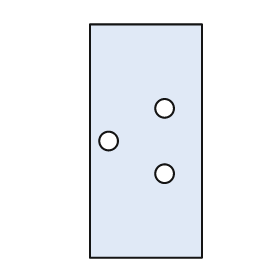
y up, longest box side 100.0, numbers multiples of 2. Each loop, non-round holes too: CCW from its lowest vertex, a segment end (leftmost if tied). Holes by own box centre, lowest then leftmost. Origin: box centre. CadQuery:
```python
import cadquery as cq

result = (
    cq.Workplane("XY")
    .moveTo(-24.0, -50.0)
    .lineTo(24.0, -50.0)
    .lineTo(24.0, 50.0)
    .lineTo(-24.0, 50.0)
    .close()
    .moveTo(8.0, -14.0)
    .circle(4.0)
    .moveTo(-16.0, 0.0)
    .circle(4.0)
    .moveTo(8.0, 14.0)
    .circle(4.0)
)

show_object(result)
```